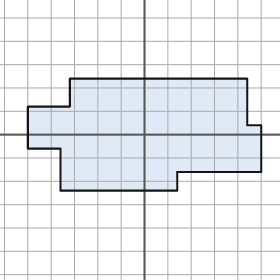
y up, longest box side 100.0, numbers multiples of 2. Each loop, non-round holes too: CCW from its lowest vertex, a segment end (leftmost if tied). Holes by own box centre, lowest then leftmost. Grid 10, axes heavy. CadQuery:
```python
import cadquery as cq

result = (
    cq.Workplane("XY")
    .moveTo(-36.0, -24.0)
    .lineTo(14.0, -24.0)
    .lineTo(14.0, -16.0)
    .lineTo(50.0, -16.0)
    .lineTo(50.0, 4.0)
    .lineTo(44.0, 4.0)
    .lineTo(44.0, 24.0)
    .lineTo(-32.0, 24.0)
    .lineTo(-32.0, 12.0)
    .lineTo(-50.0, 12.0)
    .lineTo(-50.0, -6.0)
    .lineTo(-36.0, -6.0)
    .close()
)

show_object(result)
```